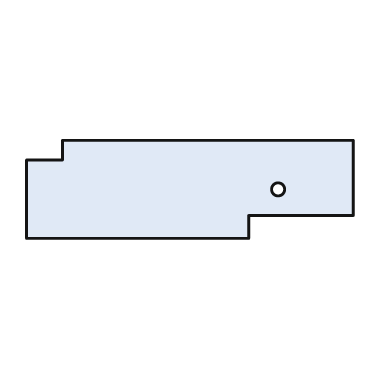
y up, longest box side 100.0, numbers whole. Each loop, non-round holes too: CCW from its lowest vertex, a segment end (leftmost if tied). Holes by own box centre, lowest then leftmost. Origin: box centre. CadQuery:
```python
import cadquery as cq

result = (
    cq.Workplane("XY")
    .moveTo(-50.0, -15.0)
    .lineTo(18.0, -15.0)
    .lineTo(18.0, -8.0)
    .lineTo(50.0, -8.0)
    .lineTo(50.0, 15.0)
    .lineTo(-39.0, 15.0)
    .lineTo(-39.0, 9.0)
    .lineTo(-50.0, 9.0)
    .close()
    .moveTo(27.0, 0.0)
    .circle(2.0)
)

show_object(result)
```